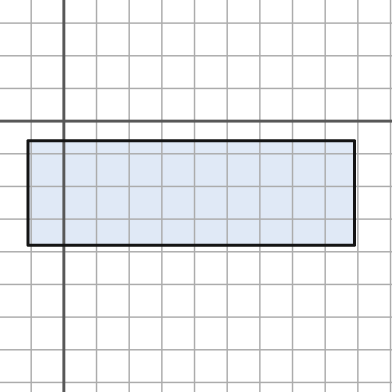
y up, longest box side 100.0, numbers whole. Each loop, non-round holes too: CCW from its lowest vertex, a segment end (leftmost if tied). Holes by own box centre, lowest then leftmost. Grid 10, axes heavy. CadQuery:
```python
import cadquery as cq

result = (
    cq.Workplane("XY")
    .moveTo(-11.0, -38.0)
    .lineTo(89.0, -38.0)
    .lineTo(89.0, -6.0)
    .lineTo(-11.0, -6.0)
    .close()
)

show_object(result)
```